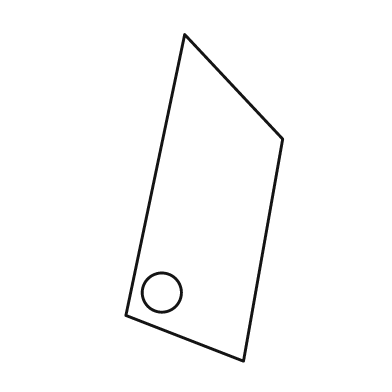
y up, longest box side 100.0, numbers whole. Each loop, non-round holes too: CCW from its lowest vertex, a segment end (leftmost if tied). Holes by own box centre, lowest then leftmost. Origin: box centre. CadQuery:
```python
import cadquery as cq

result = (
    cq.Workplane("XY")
    .moveTo(12.0, -50.0)
    .lineTo(24.0, 18.0)
    .lineTo(-6.0, 50.0)
    .lineTo(-24.0, -36.0)
    .close()
    .moveTo(-13.0, -29.0)
    .circle(6.0)
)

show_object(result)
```